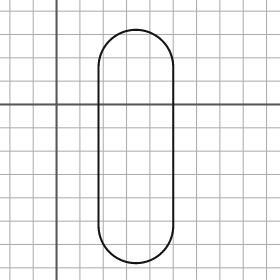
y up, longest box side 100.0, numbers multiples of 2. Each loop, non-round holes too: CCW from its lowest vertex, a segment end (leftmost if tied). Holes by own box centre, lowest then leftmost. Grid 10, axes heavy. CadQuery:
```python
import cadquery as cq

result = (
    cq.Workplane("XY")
    .moveTo(18.0, -52.0)
    .threePointArc((34.0, -68.0), (50.0, -52.0))
    .lineTo(50.0, 16.0)
    .threePointArc((34.0, 32.0), (18.0, 16.0))
    .close()
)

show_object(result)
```